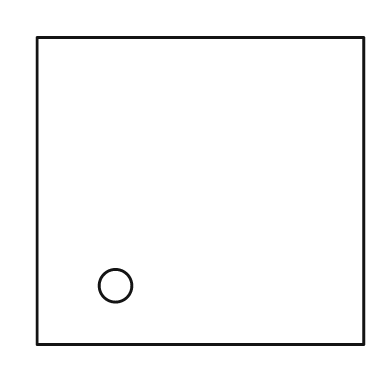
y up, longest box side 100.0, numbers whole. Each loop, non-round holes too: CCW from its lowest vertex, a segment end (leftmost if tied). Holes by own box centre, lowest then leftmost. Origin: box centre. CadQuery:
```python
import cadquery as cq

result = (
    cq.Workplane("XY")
    .moveTo(-50.0, -47.0)
    .lineTo(50.0, -47.0)
    .lineTo(50.0, 47.0)
    .lineTo(-50.0, 47.0)
    .close()
    .moveTo(-26.0, -29.0)
    .circle(5.0)
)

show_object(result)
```